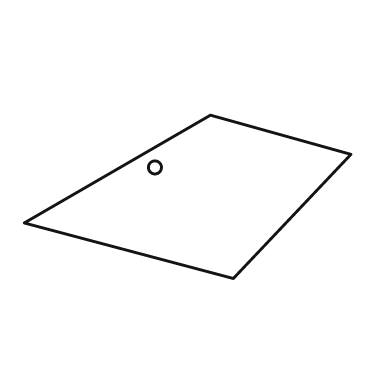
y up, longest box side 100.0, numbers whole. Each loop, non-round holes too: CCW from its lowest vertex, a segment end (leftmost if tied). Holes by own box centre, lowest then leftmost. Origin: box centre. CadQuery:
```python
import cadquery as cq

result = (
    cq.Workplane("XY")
    .moveTo(14.0, -25.0)
    .lineTo(50.0, 13.0)
    .lineTo(7.0, 25.0)
    .lineTo(-50.0, -8.0)
    .close()
    .moveTo(-10.0, 9.0)
    .circle(2.0)
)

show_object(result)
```